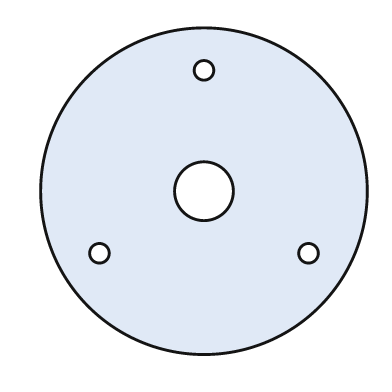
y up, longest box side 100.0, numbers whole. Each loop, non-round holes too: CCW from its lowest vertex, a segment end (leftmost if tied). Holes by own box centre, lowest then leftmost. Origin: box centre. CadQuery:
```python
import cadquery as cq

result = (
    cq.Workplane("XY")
    .moveTo(0.0, 0.0)
    .circle(50.0)
    .moveTo(-32.0, -19.0)
    .circle(3.0)
    .moveTo(32.0, -19.0)
    .circle(3.0)
    .moveTo(0.0, 0.0)
    .circle(9.0)
    .moveTo(0.0, 37.0)
    .circle(3.0)
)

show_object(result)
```